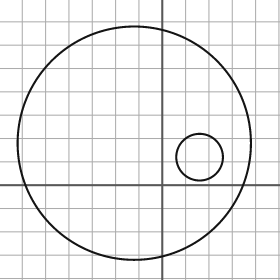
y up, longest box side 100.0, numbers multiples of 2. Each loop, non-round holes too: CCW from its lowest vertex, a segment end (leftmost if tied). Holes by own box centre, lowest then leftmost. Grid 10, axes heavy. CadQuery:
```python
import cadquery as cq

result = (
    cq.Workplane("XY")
    .moveTo(-12.0, 18.0)
    .circle(50.0)
    .moveTo(16.0, 12.0)
    .circle(10.0)
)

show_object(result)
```